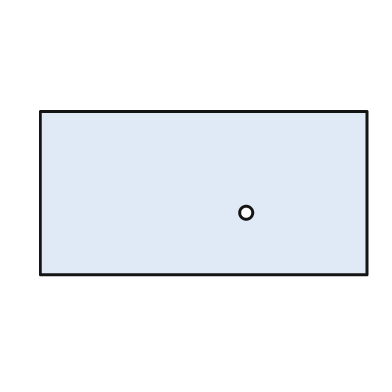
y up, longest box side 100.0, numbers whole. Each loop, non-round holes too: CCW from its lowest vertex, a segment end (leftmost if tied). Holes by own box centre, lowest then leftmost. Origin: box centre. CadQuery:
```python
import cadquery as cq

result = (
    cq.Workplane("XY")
    .moveTo(-50.0, -25.0)
    .lineTo(50.0, -25.0)
    .lineTo(50.0, 25.0)
    .lineTo(-50.0, 25.0)
    .close()
    .moveTo(13.0, -6.0)
    .circle(2.0)
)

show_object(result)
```